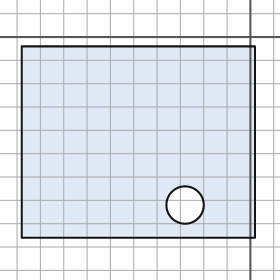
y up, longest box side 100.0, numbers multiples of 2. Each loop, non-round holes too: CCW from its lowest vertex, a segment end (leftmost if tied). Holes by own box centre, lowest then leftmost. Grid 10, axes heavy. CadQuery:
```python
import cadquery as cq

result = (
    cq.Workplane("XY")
    .moveTo(-98.0, -86.0)
    .lineTo(2.0, -86.0)
    .lineTo(2.0, -4.0)
    .lineTo(-98.0, -4.0)
    .close()
    .moveTo(-28.0, -72.0)
    .circle(8.0)
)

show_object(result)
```